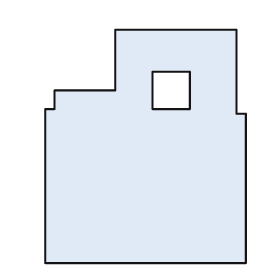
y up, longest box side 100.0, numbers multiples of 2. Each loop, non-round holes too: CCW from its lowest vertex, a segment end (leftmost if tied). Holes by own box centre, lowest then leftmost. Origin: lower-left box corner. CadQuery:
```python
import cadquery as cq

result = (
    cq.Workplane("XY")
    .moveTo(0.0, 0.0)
    .lineTo(86.0, 0.0)
    .lineTo(86.0, 64.0)
    .lineTo(82.0, 64.0)
    .lineTo(82.0, 100.0)
    .lineTo(30.0, 100.0)
    .lineTo(30.0, 74.0)
    .lineTo(4.0, 74.0)
    .lineTo(4.0, 66.0)
    .lineTo(0.0, 66.0)
    .close()
    .moveTo(46.0, 66.0)
    .lineTo(62.0, 66.0)
    .lineTo(62.0, 82.0)
    .lineTo(46.0, 82.0)
    .close()
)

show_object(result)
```